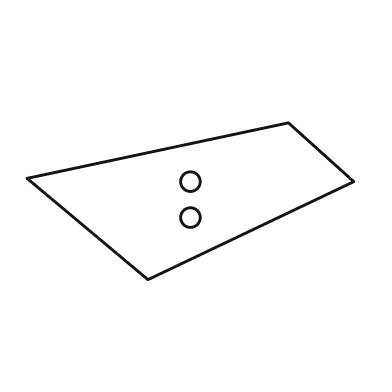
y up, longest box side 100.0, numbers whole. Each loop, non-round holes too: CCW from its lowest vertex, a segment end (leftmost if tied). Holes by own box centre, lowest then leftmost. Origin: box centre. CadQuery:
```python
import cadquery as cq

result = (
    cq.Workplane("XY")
    .moveTo(-13.0, -24.0)
    .lineTo(50.0, 6.0)
    .lineTo(30.0, 24.0)
    .lineTo(-50.0, 7.0)
    .close()
    .moveTo(0.0, -5.0)
    .circle(3.0)
    .moveTo(0.0, 6.0)
    .circle(3.0)
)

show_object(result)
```